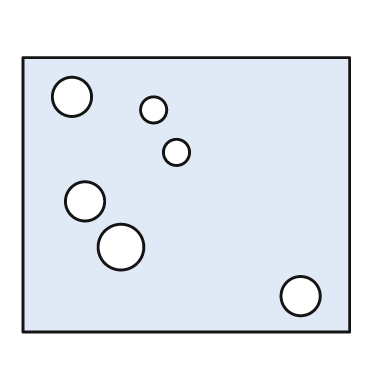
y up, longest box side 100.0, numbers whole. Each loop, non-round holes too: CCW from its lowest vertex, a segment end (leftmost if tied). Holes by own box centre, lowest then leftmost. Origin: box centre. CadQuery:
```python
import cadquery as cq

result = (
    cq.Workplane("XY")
    .moveTo(-50.0, -42.0)
    .lineTo(50.0, -42.0)
    .lineTo(50.0, 42.0)
    .lineTo(-50.0, 42.0)
    .close()
    .moveTo(35.0, -31.0)
    .circle(6.0)
    .moveTo(-20.0, -16.0)
    .circle(7.0)
    .moveTo(-31.0, -2.0)
    .circle(6.0)
    .moveTo(-3.0, 13.0)
    .circle(4.0)
    .moveTo(-10.0, 26.0)
    .circle(4.0)
    .moveTo(-35.0, 30.0)
    .circle(6.0)
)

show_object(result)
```